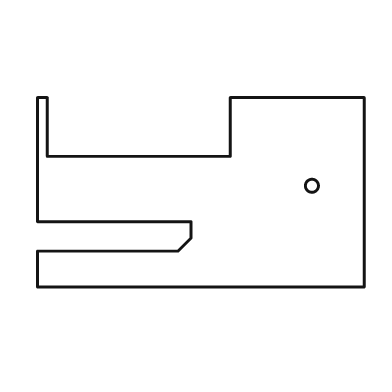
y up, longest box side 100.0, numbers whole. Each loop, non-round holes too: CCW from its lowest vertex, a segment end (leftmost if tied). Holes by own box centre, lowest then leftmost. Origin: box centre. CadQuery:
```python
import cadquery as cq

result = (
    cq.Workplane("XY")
    .moveTo(-50.0, -29.0)
    .lineTo(50.0, -29.0)
    .lineTo(50.0, 29.0)
    .lineTo(9.0, 29.0)
    .lineTo(9.0, 11.0)
    .lineTo(-47.0, 11.0)
    .lineTo(-47.0, 29.0)
    .lineTo(-50.0, 29.0)
    .lineTo(-50.0, -9.0)
    .lineTo(-3.0, -9.0)
    .lineTo(-3.0, -14.0)
    .lineTo(-7.0, -18.0)
    .lineTo(-50.0, -18.0)
    .close()
    .moveTo(34.0, 2.0)
    .circle(2.0)
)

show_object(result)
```